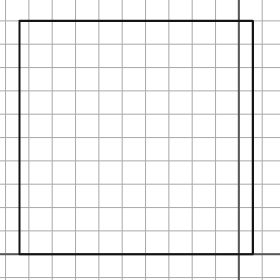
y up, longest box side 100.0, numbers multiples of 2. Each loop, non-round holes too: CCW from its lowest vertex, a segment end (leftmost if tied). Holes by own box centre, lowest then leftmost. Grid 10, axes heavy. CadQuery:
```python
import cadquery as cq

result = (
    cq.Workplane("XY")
    .moveTo(-94.0, 0.0)
    .lineTo(6.0, 0.0)
    .lineTo(6.0, 100.0)
    .lineTo(-94.0, 100.0)
    .close()
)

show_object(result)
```